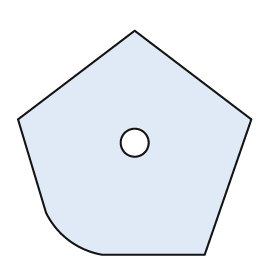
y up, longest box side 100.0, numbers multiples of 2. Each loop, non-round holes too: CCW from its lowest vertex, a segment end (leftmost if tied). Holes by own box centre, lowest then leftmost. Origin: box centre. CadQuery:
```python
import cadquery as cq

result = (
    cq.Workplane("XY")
    .moveTo(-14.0, -48.0)
    .lineTo(30.0, -48.0)
    .lineTo(50.0, 10.0)
    .lineTo(0.0, 48.0)
    .lineTo(-50.0, 10.0)
    .lineTo(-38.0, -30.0)
    .threePointArc((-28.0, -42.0), (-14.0, -48.0))
    .close()
    .moveTo(0.0, 0.0)
    .circle(6.0)
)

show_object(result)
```